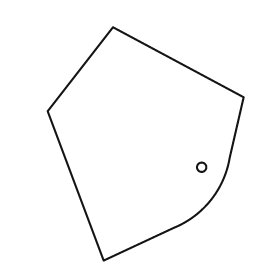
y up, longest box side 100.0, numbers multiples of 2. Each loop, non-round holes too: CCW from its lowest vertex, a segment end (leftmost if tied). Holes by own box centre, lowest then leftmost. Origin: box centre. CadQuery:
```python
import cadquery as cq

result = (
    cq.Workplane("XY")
    .moveTo(-18.0, -50.0)
    .lineTo(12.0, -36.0)
    .threePointArc((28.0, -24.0), (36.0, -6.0))
    .lineTo(42.0, 20.0)
    .lineTo(-14.0, 50.0)
    .lineTo(-42.0, 14.0)
    .close()
    .moveTo(24.0, -10.0)
    .circle(2.0)
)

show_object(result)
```